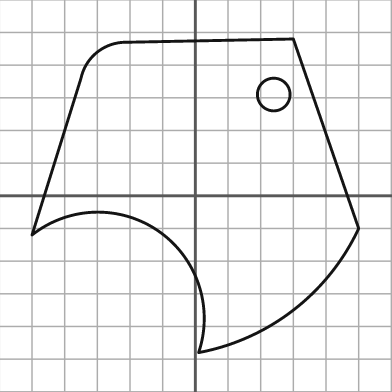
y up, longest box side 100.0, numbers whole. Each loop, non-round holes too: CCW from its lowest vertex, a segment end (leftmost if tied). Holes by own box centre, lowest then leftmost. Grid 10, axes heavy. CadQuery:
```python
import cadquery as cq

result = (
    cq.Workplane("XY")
    .moveTo(1.0, -48.0)
    .threePointArc((30.0, -35.0), (50.0, -10.0))
    .lineTo(30.0, 48.0)
    .lineTo(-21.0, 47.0)
    .threePointArc((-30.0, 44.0), (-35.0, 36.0))
    .lineTo(-50.0, -12.0)
    .threePointArc((-11.0, -11.0), (1.0, -48.0))
    .close()
    .moveTo(24.0, 31.0)
    .circle(5.0)
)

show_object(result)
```